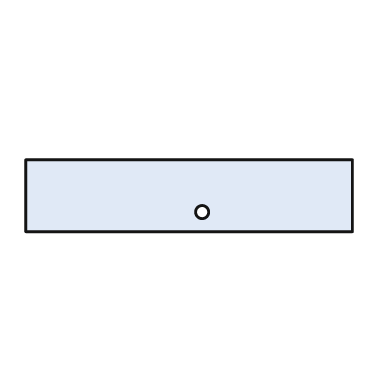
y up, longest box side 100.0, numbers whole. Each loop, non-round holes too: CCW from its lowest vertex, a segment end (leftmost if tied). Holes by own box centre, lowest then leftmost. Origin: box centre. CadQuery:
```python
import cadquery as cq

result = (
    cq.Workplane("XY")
    .moveTo(-50.0, -11.0)
    .lineTo(50.0, -11.0)
    .lineTo(50.0, 11.0)
    .lineTo(-50.0, 11.0)
    .close()
    .moveTo(4.0, -5.0)
    .circle(2.0)
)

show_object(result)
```